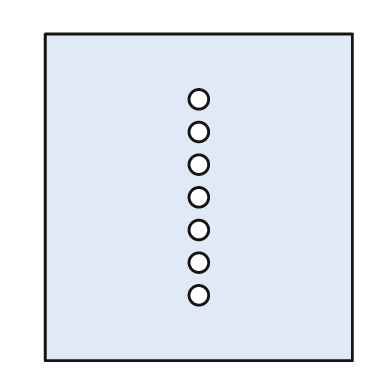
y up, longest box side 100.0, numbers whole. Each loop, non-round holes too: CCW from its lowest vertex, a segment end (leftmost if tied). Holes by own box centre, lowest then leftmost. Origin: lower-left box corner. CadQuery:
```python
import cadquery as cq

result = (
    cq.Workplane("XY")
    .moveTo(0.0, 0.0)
    .lineTo(94.0, 0.0)
    .lineTo(94.0, 100.0)
    .lineTo(0.0, 100.0)
    .close()
    .moveTo(47.0, 20.0)
    .circle(3.0)
    .moveTo(47.0, 30.0)
    .circle(3.0)
    .moveTo(47.0, 40.0)
    .circle(3.0)
    .moveTo(47.0, 50.0)
    .circle(3.0)
    .moveTo(47.0, 60.0)
    .circle(3.0)
    .moveTo(47.0, 70.0)
    .circle(3.0)
    .moveTo(47.0, 80.0)
    .circle(3.0)
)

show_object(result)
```